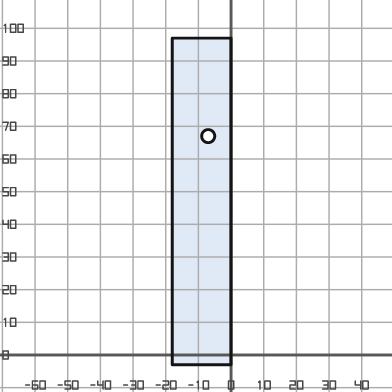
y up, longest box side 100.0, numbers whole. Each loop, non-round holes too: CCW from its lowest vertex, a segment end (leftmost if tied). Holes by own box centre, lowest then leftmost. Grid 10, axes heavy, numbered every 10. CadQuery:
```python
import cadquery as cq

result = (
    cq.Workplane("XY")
    .moveTo(-18.0, -3.0)
    .lineTo(0.0, -3.0)
    .lineTo(0.0, 97.0)
    .lineTo(-18.0, 97.0)
    .close()
    .moveTo(-7.0, 67.0)
    .circle(2.0)
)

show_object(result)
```